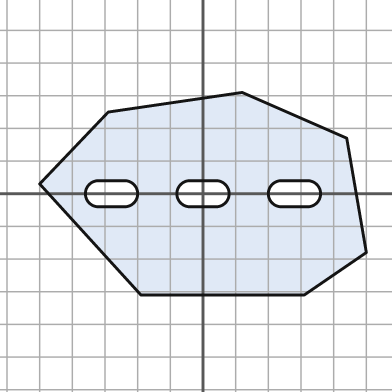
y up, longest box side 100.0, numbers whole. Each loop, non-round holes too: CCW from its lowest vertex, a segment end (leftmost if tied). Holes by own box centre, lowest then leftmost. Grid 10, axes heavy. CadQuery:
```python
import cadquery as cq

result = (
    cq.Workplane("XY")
    .moveTo(-19.0, -31.0)
    .lineTo(31.0, -31.0)
    .lineTo(50.0, -18.0)
    .lineTo(44.0, 17.0)
    .lineTo(12.0, 31.0)
    .lineTo(-29.0, 25.0)
    .lineTo(-50.0, 3.0)
    .close()
    .moveTo(-32.0, -4.0)
    .lineTo(-24.0, -4.0)
    .threePointArc((-20.0, 0.0), (-24.0, 4.0))
    .lineTo(-32.0, 4.0)
    .threePointArc((-36.0, 0.0), (-32.0, -4.0))
    .close()
    .moveTo(-4.0, -4.0)
    .lineTo(4.0, -4.0)
    .threePointArc((8.0, 0.0), (4.0, 4.0))
    .lineTo(-4.0, 4.0)
    .threePointArc((-8.0, 0.0), (-4.0, -4.0))
    .close()
    .moveTo(24.0, -4.0)
    .lineTo(32.0, -4.0)
    .threePointArc((36.0, 0.0), (32.0, 4.0))
    .lineTo(24.0, 4.0)
    .threePointArc((20.0, 0.0), (24.0, -4.0))
    .close()
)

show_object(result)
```